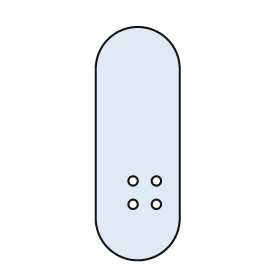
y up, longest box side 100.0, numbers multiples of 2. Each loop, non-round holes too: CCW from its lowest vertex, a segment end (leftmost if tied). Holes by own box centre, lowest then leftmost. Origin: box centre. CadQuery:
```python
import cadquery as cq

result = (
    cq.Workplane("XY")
    .moveTo(-18.0, -32.0)
    .threePointArc((0.0, -50.0), (18.0, -32.0))
    .lineTo(18.0, 32.0)
    .threePointArc((0.0, 50.0), (-18.0, 32.0))
    .close()
    .moveTo(-2.0, -26.0)
    .circle(2.0)
    .moveTo(8.0, -26.0)
    .circle(2.0)
    .moveTo(-2.0, -16.0)
    .circle(2.0)
    .moveTo(8.0, -16.0)
    .circle(2.0)
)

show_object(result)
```